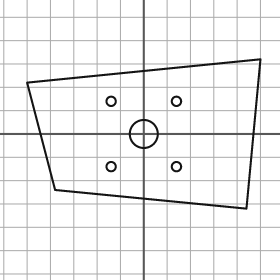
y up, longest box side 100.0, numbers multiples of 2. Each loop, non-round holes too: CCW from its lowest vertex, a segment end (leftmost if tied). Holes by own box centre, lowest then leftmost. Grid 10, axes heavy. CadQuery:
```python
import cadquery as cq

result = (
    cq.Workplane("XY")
    .moveTo(44.0, -32.0)
    .lineTo(50.0, 32.0)
    .lineTo(-50.0, 22.0)
    .lineTo(-38.0, -24.0)
    .close()
    .moveTo(-14.0, -14.0)
    .circle(2.0)
    .moveTo(14.0, -14.0)
    .circle(2.0)
    .moveTo(0.0, 0.0)
    .circle(6.0)
    .moveTo(-14.0, 14.0)
    .circle(2.0)
    .moveTo(14.0, 14.0)
    .circle(2.0)
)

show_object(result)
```